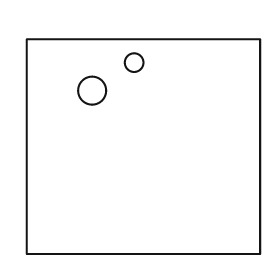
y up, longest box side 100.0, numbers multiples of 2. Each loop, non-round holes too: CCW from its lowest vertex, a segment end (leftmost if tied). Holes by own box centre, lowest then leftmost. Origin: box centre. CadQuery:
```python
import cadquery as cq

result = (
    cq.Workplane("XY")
    .moveTo(-50.0, -46.0)
    .lineTo(50.0, -46.0)
    .lineTo(50.0, 46.0)
    .lineTo(-50.0, 46.0)
    .close()
    .moveTo(-22.0, 24.0)
    .circle(6.0)
    .moveTo(-4.0, 36.0)
    .circle(4.0)
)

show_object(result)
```